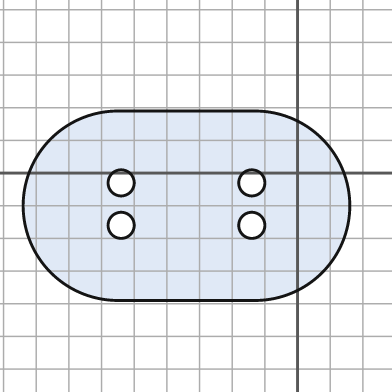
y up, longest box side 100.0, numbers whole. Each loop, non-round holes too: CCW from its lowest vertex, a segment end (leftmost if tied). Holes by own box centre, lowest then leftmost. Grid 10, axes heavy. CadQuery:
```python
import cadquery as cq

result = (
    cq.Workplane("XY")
    .moveTo(-55.0, -39.0)
    .lineTo(-13.0, -39.0)
    .threePointArc((16.0, -10.0), (-13.0, 19.0))
    .lineTo(-55.0, 19.0)
    .threePointArc((-84.0, -10.0), (-55.0, -39.0))
    .close()
    .moveTo(-54.0, -16.0)
    .circle(4.0)
    .moveTo(-14.0, -16.0)
    .circle(4.0)
    .moveTo(-54.0, -3.0)
    .circle(4.0)
    .moveTo(-14.0, -3.0)
    .circle(4.0)
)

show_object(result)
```